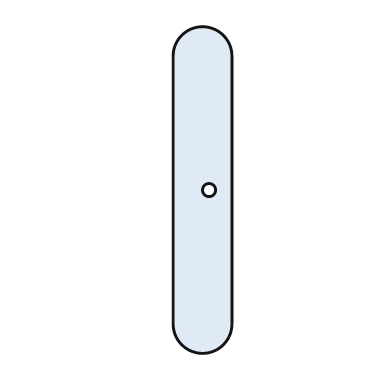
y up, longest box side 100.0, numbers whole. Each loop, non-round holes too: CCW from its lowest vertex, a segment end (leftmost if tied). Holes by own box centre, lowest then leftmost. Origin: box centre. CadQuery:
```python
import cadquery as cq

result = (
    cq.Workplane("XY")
    .moveTo(-9.0, -41.0)
    .threePointArc((0.0, -50.0), (9.0, -41.0))
    .lineTo(9.0, 41.0)
    .threePointArc((0.0, 50.0), (-9.0, 41.0))
    .close()
    .moveTo(2.0, 0.0)
    .circle(2.0)
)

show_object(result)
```